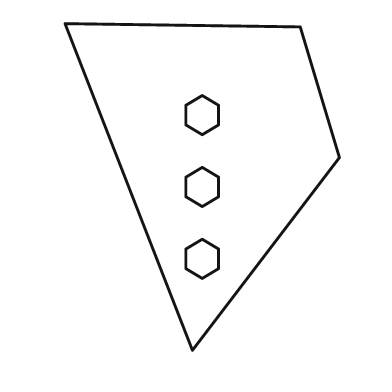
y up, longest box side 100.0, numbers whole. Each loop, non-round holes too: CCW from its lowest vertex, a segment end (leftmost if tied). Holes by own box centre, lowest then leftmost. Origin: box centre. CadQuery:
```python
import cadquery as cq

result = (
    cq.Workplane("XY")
    .moveTo(-3.0, -50.0)
    .lineTo(42.0, 9.0)
    .lineTo(30.0, 49.0)
    .lineTo(-42.0, 50.0)
    .close()
    .moveTo(0.0, -28.0)
    .lineTo(5.0, -25.0)
    .lineTo(5.0, -19.0)
    .lineTo(0.0, -16.0)
    .lineTo(-5.0, -19.0)
    .lineTo(-5.0, -25.0)
    .close()
    .moveTo(0.0, -6.0)
    .lineTo(5.0, -3.0)
    .lineTo(5.0, 3.0)
    .lineTo(0.0, 6.0)
    .lineTo(-5.0, 3.0)
    .lineTo(-5.0, -3.0)
    .close()
    .moveTo(0.0, 16.0)
    .lineTo(5.0, 19.0)
    .lineTo(5.0, 25.0)
    .lineTo(0.0, 28.0)
    .lineTo(-5.0, 25.0)
    .lineTo(-5.0, 19.0)
    .close()
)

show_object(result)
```